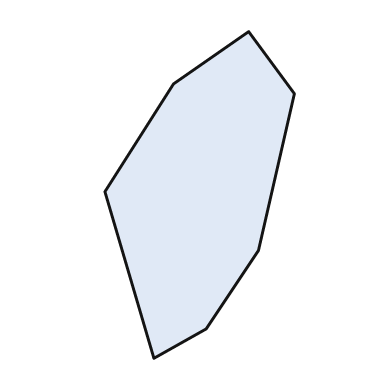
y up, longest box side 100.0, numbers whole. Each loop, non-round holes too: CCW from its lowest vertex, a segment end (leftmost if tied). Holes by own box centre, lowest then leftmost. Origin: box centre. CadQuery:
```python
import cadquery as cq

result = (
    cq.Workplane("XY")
    .moveTo(-14.0, -50.0)
    .lineTo(2.0, -41.0)
    .lineTo(18.0, -17.0)
    .lineTo(29.0, 31.0)
    .lineTo(15.0, 50.0)
    .lineTo(-8.0, 34.0)
    .lineTo(-29.0, 1.0)
    .close()
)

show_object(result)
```